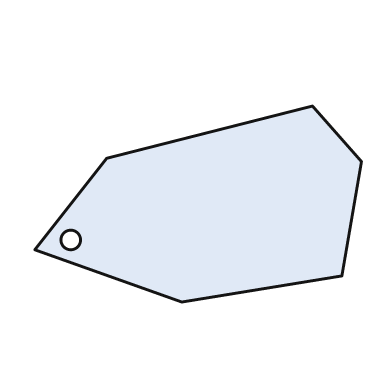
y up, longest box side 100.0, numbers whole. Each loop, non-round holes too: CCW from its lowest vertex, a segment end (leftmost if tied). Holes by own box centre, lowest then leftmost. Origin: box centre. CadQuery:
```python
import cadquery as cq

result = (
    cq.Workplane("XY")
    .moveTo(-5.0, -30.0)
    .lineTo(44.0, -22.0)
    .lineTo(50.0, 13.0)
    .lineTo(35.0, 30.0)
    .lineTo(-28.0, 14.0)
    .lineTo(-50.0, -14.0)
    .close()
    .moveTo(-39.0, -11.0)
    .circle(3.0)
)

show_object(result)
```